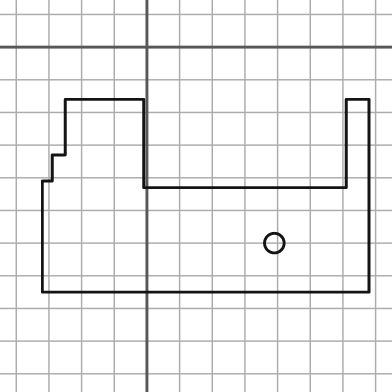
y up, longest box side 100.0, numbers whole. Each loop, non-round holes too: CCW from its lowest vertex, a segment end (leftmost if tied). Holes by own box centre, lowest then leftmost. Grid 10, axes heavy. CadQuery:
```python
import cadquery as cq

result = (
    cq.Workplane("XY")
    .moveTo(-32.0, -75.0)
    .lineTo(68.0, -75.0)
    .lineTo(68.0, -16.0)
    .lineTo(61.0, -16.0)
    .lineTo(61.0, -43.0)
    .lineTo(-1.0, -43.0)
    .lineTo(-1.0, -16.0)
    .lineTo(-25.0, -16.0)
    .lineTo(-25.0, -33.0)
    .lineTo(-29.0, -33.0)
    .lineTo(-29.0, -41.0)
    .lineTo(-32.0, -41.0)
    .close()
    .moveTo(39.0, -60.0)
    .circle(3.0)
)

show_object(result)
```